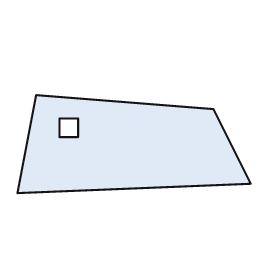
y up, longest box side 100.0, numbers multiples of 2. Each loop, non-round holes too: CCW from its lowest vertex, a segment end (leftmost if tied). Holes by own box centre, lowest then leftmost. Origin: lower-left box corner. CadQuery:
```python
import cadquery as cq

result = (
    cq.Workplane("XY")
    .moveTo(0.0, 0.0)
    .lineTo(100.0, 4.0)
    .lineTo(84.0, 36.0)
    .lineTo(8.0, 42.0)
    .close()
    .moveTo(18.0, 24.0)
    .lineTo(26.0, 24.0)
    .lineTo(26.0, 32.0)
    .lineTo(18.0, 32.0)
    .close()
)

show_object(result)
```